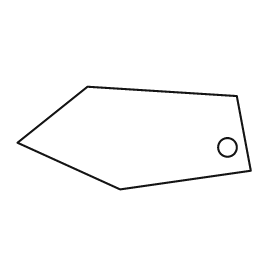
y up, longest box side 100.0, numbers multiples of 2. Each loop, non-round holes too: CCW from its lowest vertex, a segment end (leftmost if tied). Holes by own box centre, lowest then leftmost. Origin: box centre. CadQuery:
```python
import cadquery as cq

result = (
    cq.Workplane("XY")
    .moveTo(-6.0, -22.0)
    .lineTo(50.0, -14.0)
    .lineTo(44.0, 18.0)
    .lineTo(-20.0, 22.0)
    .lineTo(-50.0, -2.0)
    .close()
    .moveTo(40.0, -4.0)
    .circle(4.0)
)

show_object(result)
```